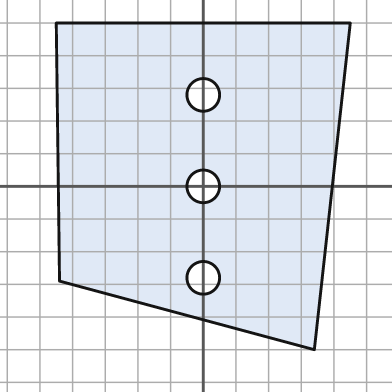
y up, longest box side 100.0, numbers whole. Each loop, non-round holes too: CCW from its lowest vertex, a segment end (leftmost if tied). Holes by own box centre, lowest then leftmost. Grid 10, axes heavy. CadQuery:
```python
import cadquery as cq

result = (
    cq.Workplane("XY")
    .moveTo(34.0, -50.0)
    .lineTo(45.0, 50.0)
    .lineTo(-45.0, 50.0)
    .lineTo(-44.0, -29.0)
    .close()
    .moveTo(0.0, -28.0)
    .circle(5.0)
    .moveTo(0.0, 0.0)
    .circle(5.0)
    .moveTo(0.0, 28.0)
    .circle(5.0)
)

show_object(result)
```